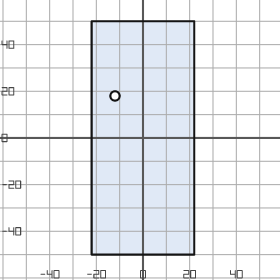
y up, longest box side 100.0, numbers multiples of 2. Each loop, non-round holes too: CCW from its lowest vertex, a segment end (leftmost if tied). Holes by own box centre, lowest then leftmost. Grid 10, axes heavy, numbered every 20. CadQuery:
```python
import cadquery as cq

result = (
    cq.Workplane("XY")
    .moveTo(-22.0, -50.0)
    .lineTo(22.0, -50.0)
    .lineTo(22.0, 50.0)
    .lineTo(-22.0, 50.0)
    .close()
    .moveTo(-12.0, 18.0)
    .circle(2.0)
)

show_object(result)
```